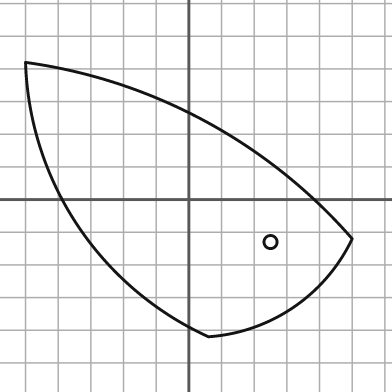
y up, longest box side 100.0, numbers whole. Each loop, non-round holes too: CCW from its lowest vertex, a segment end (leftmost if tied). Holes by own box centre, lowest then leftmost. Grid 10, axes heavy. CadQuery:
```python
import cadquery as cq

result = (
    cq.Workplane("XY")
    .moveTo(6.0, -42.0)
    .threePointArc((32.0, -33.0), (50.0, -12.0))
    .threePointArc((5.0, 24.0), (-50.0, 42.0))
    .threePointArc((-34.0, -8.0), (6.0, -42.0))
    .close()
    .moveTo(25.0, -13.0)
    .circle(2.0)
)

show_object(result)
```